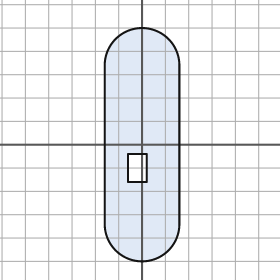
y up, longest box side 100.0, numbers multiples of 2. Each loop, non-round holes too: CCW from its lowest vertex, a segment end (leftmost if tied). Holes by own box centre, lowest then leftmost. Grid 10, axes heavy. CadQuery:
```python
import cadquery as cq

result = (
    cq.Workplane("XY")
    .moveTo(-16.0, -34.0)
    .threePointArc((0.0, -50.0), (16.0, -34.0))
    .lineTo(16.0, 34.0)
    .threePointArc((0.0, 50.0), (-16.0, 34.0))
    .close()
    .moveTo(-6.0, -16.0)
    .lineTo(2.0, -16.0)
    .lineTo(2.0, -4.0)
    .lineTo(-6.0, -4.0)
    .close()
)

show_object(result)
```